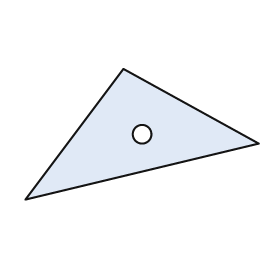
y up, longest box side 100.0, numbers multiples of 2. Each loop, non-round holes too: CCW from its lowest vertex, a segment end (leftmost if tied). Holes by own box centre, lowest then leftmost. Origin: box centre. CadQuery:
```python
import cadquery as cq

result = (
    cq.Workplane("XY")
    .moveTo(-50.0, -28.0)
    .lineTo(50.0, -4.0)
    .lineTo(-8.0, 28.0)
    .close()
    .moveTo(0.0, 0.0)
    .circle(4.0)
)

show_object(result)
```